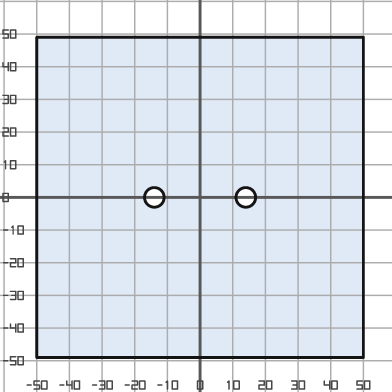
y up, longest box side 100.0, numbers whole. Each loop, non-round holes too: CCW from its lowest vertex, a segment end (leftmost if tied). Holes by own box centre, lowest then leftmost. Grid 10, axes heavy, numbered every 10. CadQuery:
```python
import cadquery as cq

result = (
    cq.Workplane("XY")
    .moveTo(-50.0, -49.0)
    .lineTo(50.0, -49.0)
    .lineTo(50.0, 49.0)
    .lineTo(-50.0, 49.0)
    .close()
    .moveTo(-14.0, 0.0)
    .circle(3.0)
    .moveTo(14.0, 0.0)
    .circle(3.0)
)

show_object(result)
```